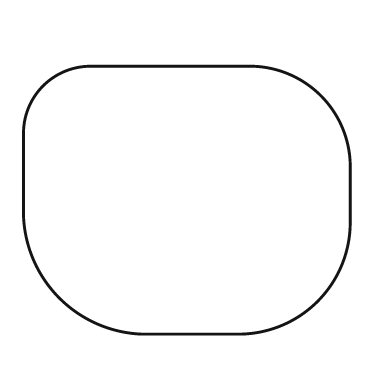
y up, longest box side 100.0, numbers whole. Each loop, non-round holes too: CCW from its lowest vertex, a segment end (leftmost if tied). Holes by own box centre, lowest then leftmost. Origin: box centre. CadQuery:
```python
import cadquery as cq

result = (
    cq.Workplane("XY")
    .moveTo(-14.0, -41.0)
    .lineTo(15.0, -41.0)
    .threePointArc((40.0, -31.0), (50.0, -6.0))
    .lineTo(50.0, 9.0)
    .threePointArc((41.0, 32.0), (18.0, 41.0))
    .lineTo(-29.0, 41.0)
    .threePointArc((-44.0, 35.0), (-50.0, 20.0))
    .lineTo(-50.0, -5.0)
    .threePointArc((-39.0, -30.0), (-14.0, -41.0))
    .close()
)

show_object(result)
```